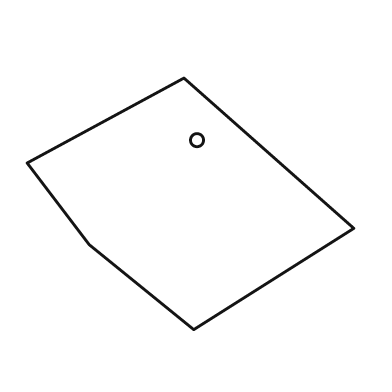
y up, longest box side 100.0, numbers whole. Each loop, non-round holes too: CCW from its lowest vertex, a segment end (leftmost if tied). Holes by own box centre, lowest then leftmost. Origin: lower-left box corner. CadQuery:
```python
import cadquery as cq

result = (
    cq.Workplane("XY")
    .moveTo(51.0, 0.0)
    .lineTo(100.0, 31.0)
    .lineTo(48.0, 77.0)
    .lineTo(0.0, 51.0)
    .lineTo(19.0, 26.0)
    .close()
    .moveTo(52.0, 58.0)
    .circle(2.0)
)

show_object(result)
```